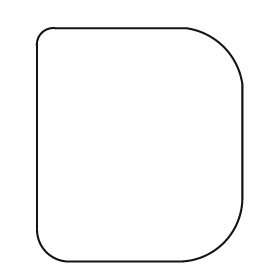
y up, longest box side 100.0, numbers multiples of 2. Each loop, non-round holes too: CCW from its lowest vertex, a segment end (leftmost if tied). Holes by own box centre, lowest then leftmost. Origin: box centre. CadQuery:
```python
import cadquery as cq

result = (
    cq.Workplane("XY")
    .moveTo(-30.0, -50.0)
    .lineTo(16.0, -50.0)
    .threePointArc((36.0, -42.0), (44.0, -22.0))
    .lineTo(44.0, 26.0)
    .threePointArc((36.0, 42.0), (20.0, 50.0))
    .lineTo(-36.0, 50.0)
    .threePointArc((-42.0, 48.0), (-44.0, 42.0))
    .lineTo(-44.0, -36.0)
    .threePointArc((-40.0, -46.0), (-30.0, -50.0))
    .close()
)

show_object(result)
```